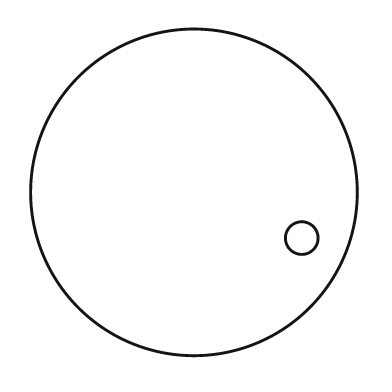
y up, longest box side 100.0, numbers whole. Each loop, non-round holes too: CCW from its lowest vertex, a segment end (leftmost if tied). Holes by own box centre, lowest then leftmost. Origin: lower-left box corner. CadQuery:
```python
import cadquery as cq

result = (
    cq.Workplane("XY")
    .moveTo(50.0, 50.0)
    .circle(50.0)
    .moveTo(83.0, 36.0)
    .circle(5.0)
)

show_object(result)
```